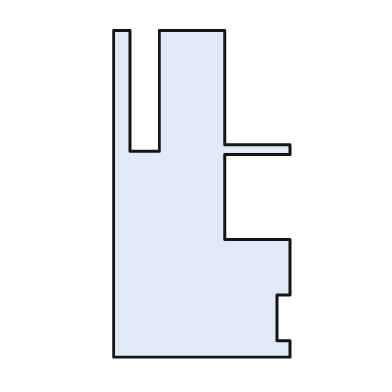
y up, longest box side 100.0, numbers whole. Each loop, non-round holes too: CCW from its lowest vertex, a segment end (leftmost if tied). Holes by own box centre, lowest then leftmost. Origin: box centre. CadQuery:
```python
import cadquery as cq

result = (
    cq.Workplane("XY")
    .moveTo(-27.0, -50.0)
    .lineTo(27.0, -50.0)
    .lineTo(27.0, -45.0)
    .lineTo(23.0, -45.0)
    .lineTo(23.0, -31.0)
    .lineTo(27.0, -31.0)
    .lineTo(27.0, -14.0)
    .lineTo(7.0, -14.0)
    .lineTo(7.0, 12.0)
    .lineTo(27.0, 12.0)
    .lineTo(27.0, 15.0)
    .lineTo(7.0, 15.0)
    .lineTo(7.0, 50.0)
    .lineTo(-13.0, 50.0)
    .lineTo(-13.0, 13.0)
    .lineTo(-22.0, 13.0)
    .lineTo(-22.0, 50.0)
    .lineTo(-27.0, 50.0)
    .close()
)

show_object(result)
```